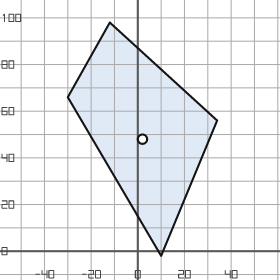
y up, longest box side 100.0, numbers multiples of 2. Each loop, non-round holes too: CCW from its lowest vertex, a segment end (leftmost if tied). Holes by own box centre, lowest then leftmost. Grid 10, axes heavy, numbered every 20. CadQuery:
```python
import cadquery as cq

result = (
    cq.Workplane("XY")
    .moveTo(10.0, -2.0)
    .lineTo(34.0, 56.0)
    .lineTo(-12.0, 98.0)
    .lineTo(-30.0, 66.0)
    .close()
    .moveTo(2.0, 48.0)
    .circle(2.0)
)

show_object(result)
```